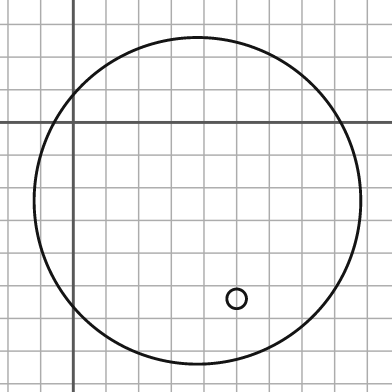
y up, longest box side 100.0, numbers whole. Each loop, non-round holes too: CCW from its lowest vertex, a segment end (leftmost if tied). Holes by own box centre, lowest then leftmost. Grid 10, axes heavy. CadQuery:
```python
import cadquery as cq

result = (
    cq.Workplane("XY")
    .moveTo(38.0, -24.0)
    .circle(50.0)
    .moveTo(50.0, -54.0)
    .circle(3.0)
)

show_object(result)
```